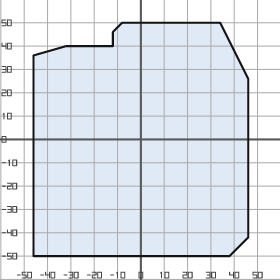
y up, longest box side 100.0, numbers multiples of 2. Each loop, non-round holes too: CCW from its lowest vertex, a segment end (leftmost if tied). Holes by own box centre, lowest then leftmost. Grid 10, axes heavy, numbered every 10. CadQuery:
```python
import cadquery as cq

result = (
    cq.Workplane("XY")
    .moveTo(-46.0, -50.0)
    .lineTo(38.0, -50.0)
    .lineTo(46.0, -42.0)
    .lineTo(46.0, 26.0)
    .lineTo(34.0, 50.0)
    .lineTo(-8.0, 50.0)
    .lineTo(-12.0, 46.0)
    .lineTo(-12.0, 40.0)
    .lineTo(-32.0, 40.0)
    .lineTo(-46.0, 36.0)
    .close()
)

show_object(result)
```